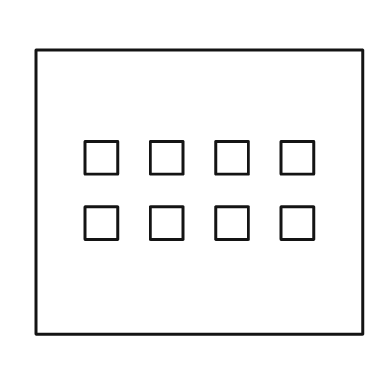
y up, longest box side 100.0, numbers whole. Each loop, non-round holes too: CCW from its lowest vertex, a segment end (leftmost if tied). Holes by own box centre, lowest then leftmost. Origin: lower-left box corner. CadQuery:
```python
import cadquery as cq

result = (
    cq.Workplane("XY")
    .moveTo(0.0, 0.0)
    .lineTo(100.0, 0.0)
    .lineTo(100.0, 87.0)
    .lineTo(0.0, 87.0)
    .close()
    .moveTo(15.0, 29.0)
    .lineTo(25.0, 29.0)
    .lineTo(25.0, 39.0)
    .lineTo(15.0, 39.0)
    .close()
    .moveTo(35.0, 29.0)
    .lineTo(45.0, 29.0)
    .lineTo(45.0, 39.0)
    .lineTo(35.0, 39.0)
    .close()
    .moveTo(55.0, 29.0)
    .lineTo(65.0, 29.0)
    .lineTo(65.0, 39.0)
    .lineTo(55.0, 39.0)
    .close()
    .moveTo(75.0, 29.0)
    .lineTo(85.0, 29.0)
    .lineTo(85.0, 39.0)
    .lineTo(75.0, 39.0)
    .close()
    .moveTo(15.0, 49.0)
    .lineTo(25.0, 49.0)
    .lineTo(25.0, 59.0)
    .lineTo(15.0, 59.0)
    .close()
    .moveTo(35.0, 49.0)
    .lineTo(45.0, 49.0)
    .lineTo(45.0, 59.0)
    .lineTo(35.0, 59.0)
    .close()
    .moveTo(55.0, 49.0)
    .lineTo(65.0, 49.0)
    .lineTo(65.0, 59.0)
    .lineTo(55.0, 59.0)
    .close()
    .moveTo(75.0, 49.0)
    .lineTo(85.0, 49.0)
    .lineTo(85.0, 59.0)
    .lineTo(75.0, 59.0)
    .close()
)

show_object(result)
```